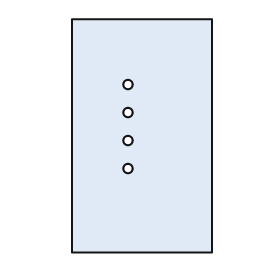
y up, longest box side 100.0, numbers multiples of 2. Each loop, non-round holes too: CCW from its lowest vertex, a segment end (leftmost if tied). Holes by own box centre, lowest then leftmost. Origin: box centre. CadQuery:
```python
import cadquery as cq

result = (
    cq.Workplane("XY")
    .moveTo(-30.0, -50.0)
    .lineTo(30.0, -50.0)
    .lineTo(30.0, 50.0)
    .lineTo(-30.0, 50.0)
    .close()
    .moveTo(-6.0, -14.0)
    .circle(2.0)
    .moveTo(-6.0, -2.0)
    .circle(2.0)
    .moveTo(-6.0, 10.0)
    .circle(2.0)
    .moveTo(-6.0, 22.0)
    .circle(2.0)
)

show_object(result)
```